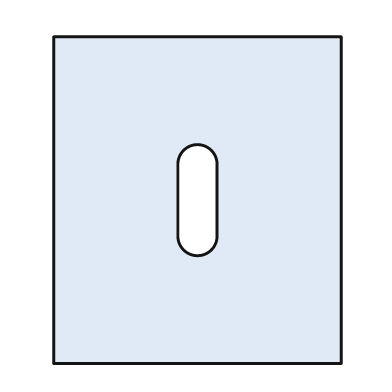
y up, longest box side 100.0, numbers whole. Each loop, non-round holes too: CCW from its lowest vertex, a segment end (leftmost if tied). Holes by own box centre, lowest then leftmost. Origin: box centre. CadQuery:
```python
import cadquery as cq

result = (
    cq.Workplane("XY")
    .moveTo(-44.0, -50.0)
    .lineTo(44.0, -50.0)
    .lineTo(44.0, 50.0)
    .lineTo(-44.0, 50.0)
    .close()
    .moveTo(-6.0, -11.0)
    .threePointArc((0.0, -17.0), (6.0, -11.0))
    .lineTo(6.0, 11.0)
    .threePointArc((0.0, 17.0), (-6.0, 11.0))
    .close()
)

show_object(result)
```